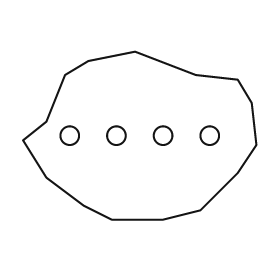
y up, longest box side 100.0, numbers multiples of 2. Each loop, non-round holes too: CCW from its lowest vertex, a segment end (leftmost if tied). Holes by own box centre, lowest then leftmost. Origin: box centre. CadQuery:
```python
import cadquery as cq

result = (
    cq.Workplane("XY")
    .moveTo(-12.0, -36.0)
    .lineTo(10.0, -36.0)
    .lineTo(26.0, -32.0)
    .lineTo(42.0, -16.0)
    .lineTo(50.0, -4.0)
    .lineTo(48.0, 14.0)
    .lineTo(42.0, 24.0)
    .lineTo(24.0, 26.0)
    .lineTo(-2.0, 36.0)
    .lineTo(-22.0, 32.0)
    .lineTo(-32.0, 26.0)
    .lineTo(-40.0, 6.0)
    .lineTo(-50.0, -2.0)
    .lineTo(-40.0, -18.0)
    .lineTo(-24.0, -30.0)
    .close()
    .moveTo(-30.0, 0.0)
    .circle(4.0)
    .moveTo(-10.0, 0.0)
    .circle(4.0)
    .moveTo(10.0, 0.0)
    .circle(4.0)
    .moveTo(30.0, 0.0)
    .circle(4.0)
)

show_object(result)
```